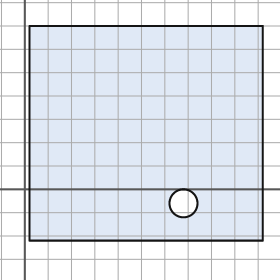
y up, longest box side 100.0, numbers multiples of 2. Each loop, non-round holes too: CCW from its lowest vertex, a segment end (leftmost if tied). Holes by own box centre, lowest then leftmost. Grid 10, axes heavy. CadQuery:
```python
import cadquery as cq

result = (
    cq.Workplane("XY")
    .moveTo(2.0, -22.0)
    .lineTo(102.0, -22.0)
    .lineTo(102.0, 70.0)
    .lineTo(2.0, 70.0)
    .close()
    .moveTo(68.0, -6.0)
    .circle(6.0)
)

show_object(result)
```